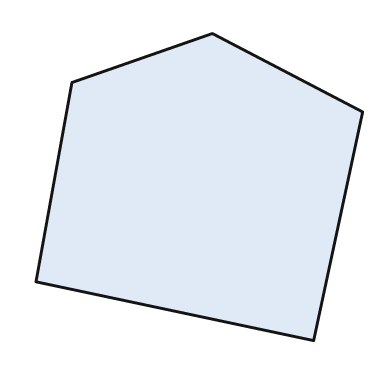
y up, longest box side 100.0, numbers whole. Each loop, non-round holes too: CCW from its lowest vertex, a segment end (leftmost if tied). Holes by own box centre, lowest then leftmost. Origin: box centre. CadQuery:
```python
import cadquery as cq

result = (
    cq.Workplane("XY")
    .moveTo(35.0, -47.0)
    .lineTo(50.0, 23.0)
    .lineTo(4.0, 47.0)
    .lineTo(-39.0, 32.0)
    .lineTo(-50.0, -29.0)
    .close()
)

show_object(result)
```